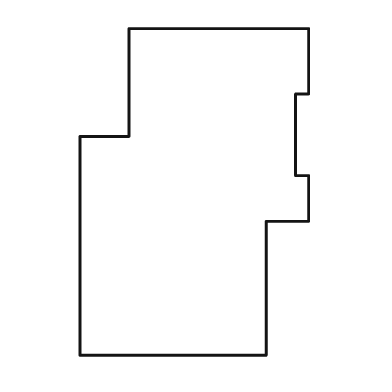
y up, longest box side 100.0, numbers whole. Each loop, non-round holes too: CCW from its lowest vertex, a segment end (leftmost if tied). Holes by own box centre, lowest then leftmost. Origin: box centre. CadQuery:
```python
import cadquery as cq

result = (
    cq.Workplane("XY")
    .moveTo(-35.0, -50.0)
    .lineTo(22.0, -50.0)
    .lineTo(22.0, -9.0)
    .lineTo(35.0, -9.0)
    .lineTo(35.0, 5.0)
    .lineTo(31.0, 5.0)
    .lineTo(31.0, 30.0)
    .lineTo(35.0, 30.0)
    .lineTo(35.0, 50.0)
    .lineTo(-20.0, 50.0)
    .lineTo(-20.0, 17.0)
    .lineTo(-35.0, 17.0)
    .close()
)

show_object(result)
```